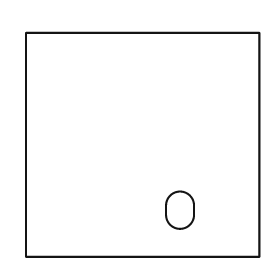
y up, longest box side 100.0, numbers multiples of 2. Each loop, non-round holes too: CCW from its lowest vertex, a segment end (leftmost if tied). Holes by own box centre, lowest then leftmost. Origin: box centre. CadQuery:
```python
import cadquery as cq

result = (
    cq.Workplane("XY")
    .moveTo(-50.0, -48.0)
    .lineTo(50.0, -48.0)
    .lineTo(50.0, 48.0)
    .lineTo(-50.0, 48.0)
    .close()
    .moveTo(10.0, -30.0)
    .threePointArc((16.0, -36.0), (22.0, -30.0))
    .lineTo(22.0, -26.0)
    .threePointArc((16.0, -20.0), (10.0, -26.0))
    .close()
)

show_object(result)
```